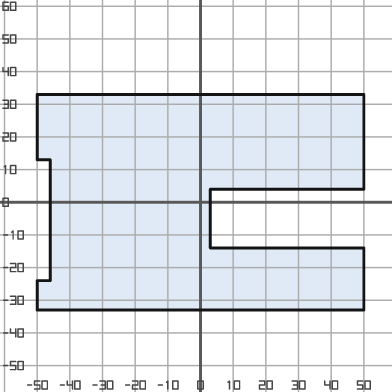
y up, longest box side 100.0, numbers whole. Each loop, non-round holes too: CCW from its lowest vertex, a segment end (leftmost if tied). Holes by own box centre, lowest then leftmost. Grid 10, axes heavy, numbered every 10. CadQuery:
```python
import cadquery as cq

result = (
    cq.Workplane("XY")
    .moveTo(-50.0, -33.0)
    .lineTo(50.0, -33.0)
    .lineTo(50.0, -14.0)
    .lineTo(3.0, -14.0)
    .lineTo(3.0, 4.0)
    .lineTo(50.0, 4.0)
    .lineTo(50.0, 33.0)
    .lineTo(-50.0, 33.0)
    .lineTo(-50.0, 13.0)
    .lineTo(-46.0, 13.0)
    .lineTo(-46.0, -24.0)
    .lineTo(-50.0, -24.0)
    .close()
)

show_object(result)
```